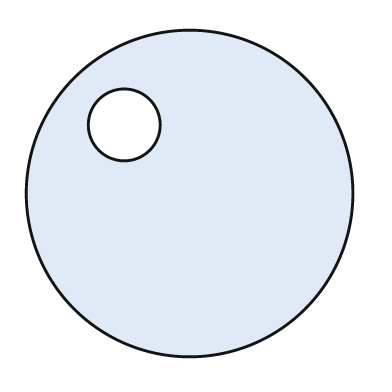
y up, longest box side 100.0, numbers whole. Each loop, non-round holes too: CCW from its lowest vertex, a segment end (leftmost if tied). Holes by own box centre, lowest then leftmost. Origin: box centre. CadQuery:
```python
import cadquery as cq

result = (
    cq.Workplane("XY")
    .moveTo(0.0, 0.0)
    .circle(50.0)
    .moveTo(-20.0, 21.0)
    .circle(11.0)
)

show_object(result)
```